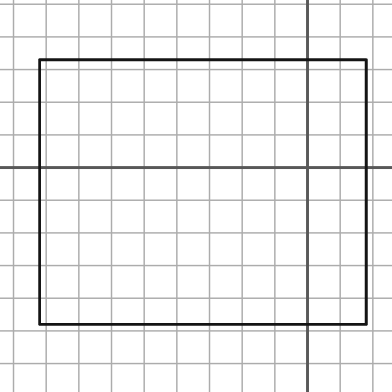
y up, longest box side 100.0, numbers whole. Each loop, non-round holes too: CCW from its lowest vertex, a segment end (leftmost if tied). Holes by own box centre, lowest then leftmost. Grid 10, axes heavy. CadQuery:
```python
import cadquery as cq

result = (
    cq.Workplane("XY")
    .moveTo(-82.0, -48.0)
    .lineTo(18.0, -48.0)
    .lineTo(18.0, 33.0)
    .lineTo(-82.0, 33.0)
    .close()
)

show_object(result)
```